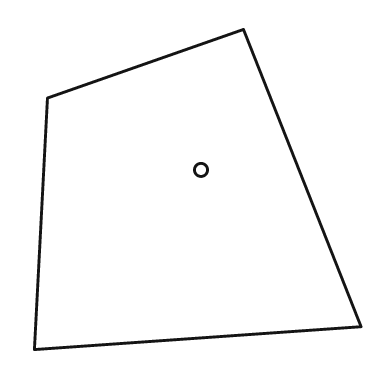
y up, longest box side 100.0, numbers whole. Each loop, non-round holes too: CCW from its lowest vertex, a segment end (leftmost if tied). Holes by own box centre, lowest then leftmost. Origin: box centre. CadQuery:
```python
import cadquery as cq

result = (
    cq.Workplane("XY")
    .moveTo(-50.0, -49.0)
    .lineTo(50.0, -42.0)
    .lineTo(14.0, 49.0)
    .lineTo(-46.0, 28.0)
    .close()
    .moveTo(1.0, 6.0)
    .circle(2.0)
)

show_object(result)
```